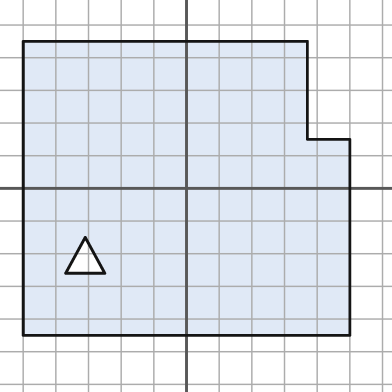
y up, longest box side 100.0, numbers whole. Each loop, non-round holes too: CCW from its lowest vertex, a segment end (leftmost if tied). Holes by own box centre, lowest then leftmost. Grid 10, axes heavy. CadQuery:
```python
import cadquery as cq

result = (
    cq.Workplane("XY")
    .moveTo(-50.0, -45.0)
    .lineTo(50.0, -45.0)
    .lineTo(50.0, 15.0)
    .lineTo(37.0, 15.0)
    .lineTo(37.0, 45.0)
    .lineTo(-50.0, 45.0)
    .close()
    .moveTo(-37.0, -26.0)
    .lineTo(-25.0, -26.0)
    .lineTo(-31.0, -15.0)
    .close()
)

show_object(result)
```